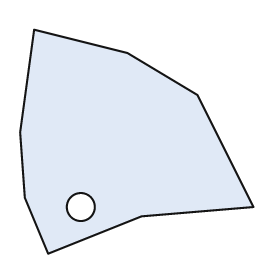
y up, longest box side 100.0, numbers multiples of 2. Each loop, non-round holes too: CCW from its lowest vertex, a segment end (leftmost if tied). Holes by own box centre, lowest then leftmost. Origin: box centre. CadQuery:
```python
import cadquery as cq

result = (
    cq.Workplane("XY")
    .moveTo(-38.0, -48.0)
    .lineTo(2.0, -32.0)
    .lineTo(50.0, -28.0)
    .lineTo(26.0, 20.0)
    .lineTo(-4.0, 38.0)
    .lineTo(-44.0, 48.0)
    .lineTo(-50.0, 4.0)
    .lineTo(-48.0, -24.0)
    .close()
    .moveTo(-24.0, -28.0)
    .circle(6.0)
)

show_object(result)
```